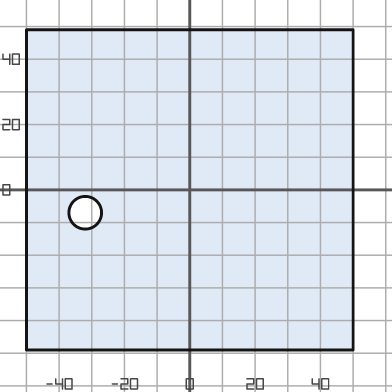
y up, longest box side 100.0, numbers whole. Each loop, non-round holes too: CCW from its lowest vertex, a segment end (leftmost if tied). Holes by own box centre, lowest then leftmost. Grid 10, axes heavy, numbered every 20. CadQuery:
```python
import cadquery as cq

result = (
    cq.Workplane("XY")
    .moveTo(-50.0, -49.0)
    .lineTo(50.0, -49.0)
    .lineTo(50.0, 49.0)
    .lineTo(-50.0, 49.0)
    .close()
    .moveTo(-32.0, -7.0)
    .circle(5.0)
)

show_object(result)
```